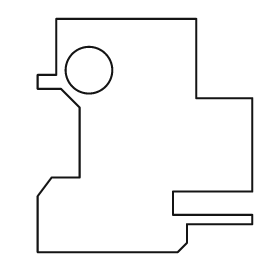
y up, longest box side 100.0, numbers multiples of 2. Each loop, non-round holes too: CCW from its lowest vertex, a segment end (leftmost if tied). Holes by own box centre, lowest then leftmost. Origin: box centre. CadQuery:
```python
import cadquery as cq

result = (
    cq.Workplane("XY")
    .moveTo(-46.0, -50.0)
    .lineTo(14.0, -50.0)
    .lineTo(18.0, -46.0)
    .lineTo(18.0, -38.0)
    .lineTo(46.0, -38.0)
    .lineTo(46.0, -34.0)
    .lineTo(12.0, -34.0)
    .lineTo(12.0, -24.0)
    .lineTo(46.0, -24.0)
    .lineTo(46.0, 16.0)
    .lineTo(22.0, 16.0)
    .lineTo(22.0, 50.0)
    .lineTo(-38.0, 50.0)
    .lineTo(-38.0, 26.0)
    .lineTo(-46.0, 26.0)
    .lineTo(-46.0, 20.0)
    .lineTo(-36.0, 20.0)
    .lineTo(-28.0, 12.0)
    .lineTo(-28.0, -18.0)
    .lineTo(-40.0, -18.0)
    .lineTo(-46.0, -26.0)
    .close()
    .moveTo(-24.0, 28.0)
    .circle(10.0)
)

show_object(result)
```